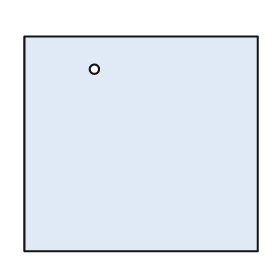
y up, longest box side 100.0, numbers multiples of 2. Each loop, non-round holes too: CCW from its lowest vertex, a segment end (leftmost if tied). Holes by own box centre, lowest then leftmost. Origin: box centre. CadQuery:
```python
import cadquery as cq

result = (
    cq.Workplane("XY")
    .moveTo(-50.0, -46.0)
    .lineTo(50.0, -46.0)
    .lineTo(50.0, 46.0)
    .lineTo(-50.0, 46.0)
    .close()
    .moveTo(-20.0, 32.0)
    .circle(2.0)
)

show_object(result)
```